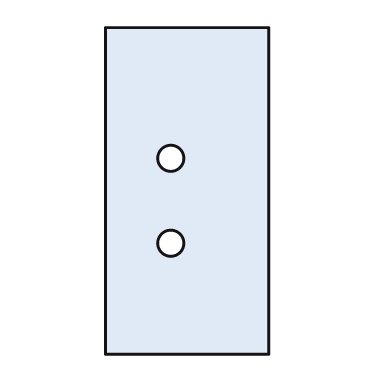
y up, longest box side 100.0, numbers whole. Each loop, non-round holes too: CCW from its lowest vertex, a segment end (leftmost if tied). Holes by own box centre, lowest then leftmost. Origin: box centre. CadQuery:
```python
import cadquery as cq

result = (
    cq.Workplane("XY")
    .moveTo(-25.0, -50.0)
    .lineTo(25.0, -50.0)
    .lineTo(25.0, 50.0)
    .lineTo(-25.0, 50.0)
    .close()
    .moveTo(-5.0, -16.0)
    .circle(4.0)
    .moveTo(-5.0, 10.0)
    .circle(4.0)
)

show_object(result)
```